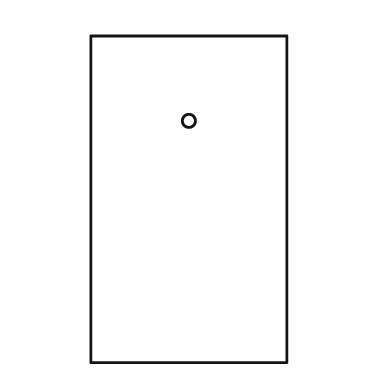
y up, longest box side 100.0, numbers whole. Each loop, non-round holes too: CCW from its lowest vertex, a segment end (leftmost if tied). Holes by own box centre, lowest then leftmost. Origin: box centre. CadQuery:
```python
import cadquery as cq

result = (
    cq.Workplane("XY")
    .moveTo(-30.0, -50.0)
    .lineTo(30.0, -50.0)
    .lineTo(30.0, 50.0)
    .lineTo(-30.0, 50.0)
    .close()
    .moveTo(0.0, 24.0)
    .circle(2.0)
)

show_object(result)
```